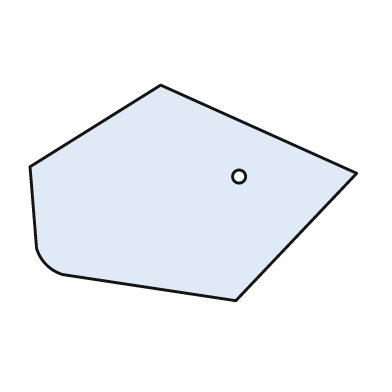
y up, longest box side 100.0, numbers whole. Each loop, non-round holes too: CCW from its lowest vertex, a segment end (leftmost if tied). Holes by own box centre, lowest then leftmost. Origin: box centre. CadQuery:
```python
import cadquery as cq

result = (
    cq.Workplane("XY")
    .moveTo(13.0, -33.0)
    .lineTo(50.0, 6.0)
    .lineTo(-10.0, 33.0)
    .lineTo(-50.0, 8.0)
    .lineTo(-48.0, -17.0)
    .threePointArc((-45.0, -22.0), (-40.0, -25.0))
    .close()
    .moveTo(14.0, 5.0)
    .circle(2.0)
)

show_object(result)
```